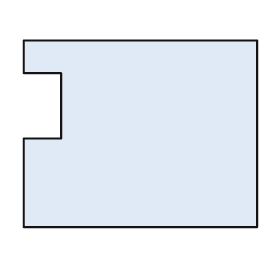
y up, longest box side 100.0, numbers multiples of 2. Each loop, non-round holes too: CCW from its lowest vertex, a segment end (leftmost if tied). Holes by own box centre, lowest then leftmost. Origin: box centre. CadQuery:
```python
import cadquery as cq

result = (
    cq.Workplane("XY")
    .moveTo(-50.0, -40.0)
    .lineTo(50.0, -40.0)
    .lineTo(50.0, 40.0)
    .lineTo(-50.0, 40.0)
    .lineTo(-50.0, 26.0)
    .lineTo(-34.0, 26.0)
    .lineTo(-34.0, -2.0)
    .lineTo(-50.0, -2.0)
    .close()
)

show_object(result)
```